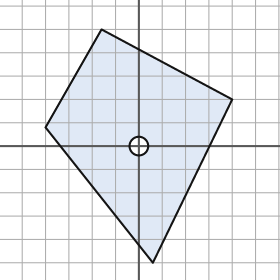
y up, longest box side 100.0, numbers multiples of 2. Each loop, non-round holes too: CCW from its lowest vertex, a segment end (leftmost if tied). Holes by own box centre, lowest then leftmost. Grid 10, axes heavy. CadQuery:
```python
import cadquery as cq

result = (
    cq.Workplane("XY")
    .moveTo(6.0, -50.0)
    .lineTo(40.0, 20.0)
    .lineTo(-16.0, 50.0)
    .lineTo(-40.0, 8.0)
    .close()
    .moveTo(0.0, 0.0)
    .circle(4.0)
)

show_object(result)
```